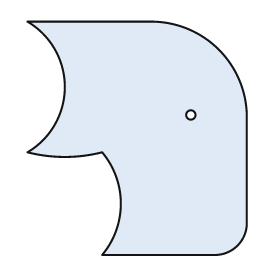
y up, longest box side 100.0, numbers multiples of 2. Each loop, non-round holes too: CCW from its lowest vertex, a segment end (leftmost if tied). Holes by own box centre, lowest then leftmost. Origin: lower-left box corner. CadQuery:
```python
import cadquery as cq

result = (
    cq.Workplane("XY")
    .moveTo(32.0, 0.0)
    .lineTo(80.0, 0.0)
    .threePointArc((90.0, 4.0), (94.0, 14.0))
    .lineTo(94.0, 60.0)
    .threePointArc((82.0, 88.0), (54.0, 100.0))
    .lineTo(0.0, 100.0)
    .threePointArc((16.0, 72.0), (0.0, 44.0))
    .threePointArc((16.0, 42.0), (32.0, 44.0))
    .threePointArc((40.0, 22.0), (32.0, 0.0))
    .close()
    .moveTo(70.0, 60.0)
    .circle(2.0)
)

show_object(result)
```